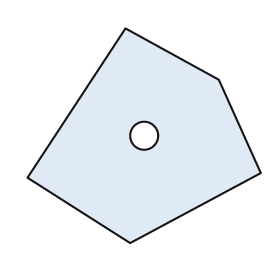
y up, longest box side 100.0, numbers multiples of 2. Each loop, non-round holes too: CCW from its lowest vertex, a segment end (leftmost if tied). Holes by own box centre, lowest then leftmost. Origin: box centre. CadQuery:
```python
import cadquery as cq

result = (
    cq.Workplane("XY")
    .moveTo(-6.0, -46.0)
    .lineTo(50.0, -16.0)
    .lineTo(32.0, 24.0)
    .lineTo(-8.0, 46.0)
    .lineTo(-50.0, -18.0)
    .close()
    .moveTo(0.0, 0.0)
    .circle(6.0)
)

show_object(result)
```